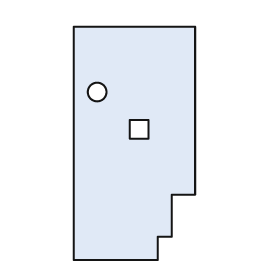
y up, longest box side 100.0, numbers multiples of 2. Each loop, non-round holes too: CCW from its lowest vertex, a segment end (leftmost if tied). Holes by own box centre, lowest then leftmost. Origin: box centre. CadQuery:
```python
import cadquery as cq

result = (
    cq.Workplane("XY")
    .moveTo(-26.0, -50.0)
    .lineTo(10.0, -50.0)
    .lineTo(10.0, -40.0)
    .lineTo(16.0, -40.0)
    .lineTo(16.0, -22.0)
    .lineTo(26.0, -22.0)
    .lineTo(26.0, 50.0)
    .lineTo(-26.0, 50.0)
    .close()
    .moveTo(-2.0, 2.0)
    .lineTo(6.0, 2.0)
    .lineTo(6.0, 10.0)
    .lineTo(-2.0, 10.0)
    .close()
    .moveTo(-16.0, 22.0)
    .circle(4.0)
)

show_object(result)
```